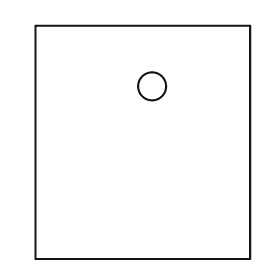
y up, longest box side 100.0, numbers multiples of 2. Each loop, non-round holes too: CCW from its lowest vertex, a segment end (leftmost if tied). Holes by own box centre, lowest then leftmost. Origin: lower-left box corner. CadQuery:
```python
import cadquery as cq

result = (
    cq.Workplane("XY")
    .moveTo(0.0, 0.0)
    .lineTo(92.0, 0.0)
    .lineTo(92.0, 100.0)
    .lineTo(0.0, 100.0)
    .close()
    .moveTo(50.0, 74.0)
    .circle(6.0)
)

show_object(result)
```